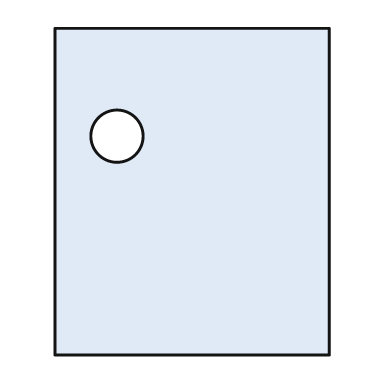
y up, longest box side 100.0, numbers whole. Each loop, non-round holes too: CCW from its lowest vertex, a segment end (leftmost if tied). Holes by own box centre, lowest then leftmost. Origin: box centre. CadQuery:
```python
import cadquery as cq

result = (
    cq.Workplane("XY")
    .moveTo(-42.0, -50.0)
    .lineTo(42.0, -50.0)
    .lineTo(42.0, 50.0)
    .lineTo(-42.0, 50.0)
    .close()
    .moveTo(-23.0, 17.0)
    .circle(8.0)
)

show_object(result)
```